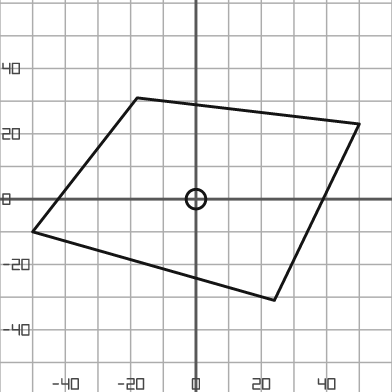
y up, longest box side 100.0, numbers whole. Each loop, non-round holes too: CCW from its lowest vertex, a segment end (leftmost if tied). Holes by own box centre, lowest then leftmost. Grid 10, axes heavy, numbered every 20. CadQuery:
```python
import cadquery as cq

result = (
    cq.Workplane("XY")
    .moveTo(24.0, -31.0)
    .lineTo(50.0, 23.0)
    .lineTo(-18.0, 31.0)
    .lineTo(-50.0, -10.0)
    .close()
    .moveTo(0.0, 0.0)
    .circle(3.0)
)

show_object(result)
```